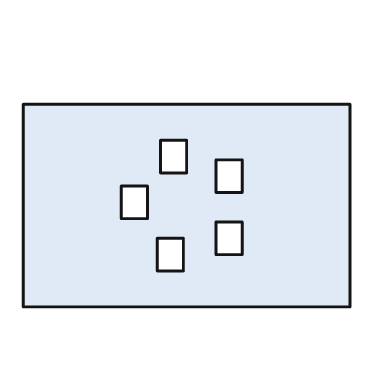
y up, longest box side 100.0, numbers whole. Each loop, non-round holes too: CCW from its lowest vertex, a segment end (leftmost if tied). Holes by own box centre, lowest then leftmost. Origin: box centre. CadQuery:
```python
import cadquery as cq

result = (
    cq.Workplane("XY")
    .moveTo(-50.0, -31.0)
    .lineTo(50.0, -31.0)
    .lineTo(50.0, 31.0)
    .lineTo(-50.0, 31.0)
    .close()
    .moveTo(-9.0, -20.0)
    .lineTo(-1.0, -20.0)
    .lineTo(-1.0, -10.0)
    .lineTo(-9.0, -10.0)
    .close()
    .moveTo(9.0, -15.0)
    .lineTo(17.0, -15.0)
    .lineTo(17.0, -5.0)
    .lineTo(9.0, -5.0)
    .close()
    .moveTo(-20.0, -4.0)
    .lineTo(-12.0, -4.0)
    .lineTo(-12.0, 6.0)
    .lineTo(-20.0, 6.0)
    .close()
    .moveTo(9.0, 4.0)
    .lineTo(17.0, 4.0)
    .lineTo(17.0, 14.0)
    .lineTo(9.0, 14.0)
    .close()
    .moveTo(-8.0, 10.0)
    .lineTo(0.0, 10.0)
    .lineTo(0.0, 20.0)
    .lineTo(-8.0, 20.0)
    .close()
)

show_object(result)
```